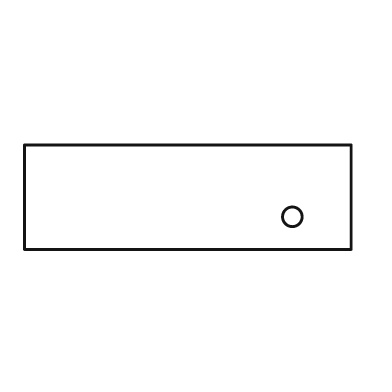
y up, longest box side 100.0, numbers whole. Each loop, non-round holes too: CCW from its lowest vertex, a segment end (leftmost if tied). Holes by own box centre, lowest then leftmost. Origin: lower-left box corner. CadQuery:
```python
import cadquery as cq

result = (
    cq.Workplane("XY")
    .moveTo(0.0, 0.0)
    .lineTo(100.0, 0.0)
    .lineTo(100.0, 32.0)
    .lineTo(0.0, 32.0)
    .close()
    .moveTo(82.0, 10.0)
    .circle(3.0)
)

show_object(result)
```